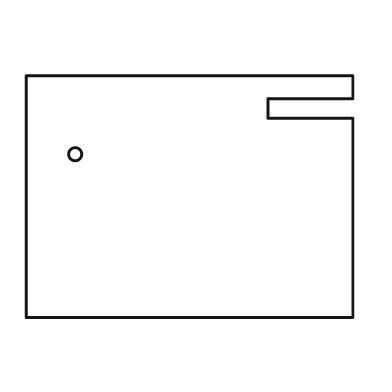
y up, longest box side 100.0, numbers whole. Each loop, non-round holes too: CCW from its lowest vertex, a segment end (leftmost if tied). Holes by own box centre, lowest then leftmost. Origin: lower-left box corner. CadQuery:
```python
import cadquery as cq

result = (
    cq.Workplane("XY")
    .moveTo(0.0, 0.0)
    .lineTo(100.0, 0.0)
    .lineTo(100.0, 61.0)
    .lineTo(74.0, 61.0)
    .lineTo(74.0, 67.0)
    .lineTo(100.0, 67.0)
    .lineTo(100.0, 74.0)
    .lineTo(0.0, 74.0)
    .close()
    .moveTo(15.0, 50.0)
    .circle(2.0)
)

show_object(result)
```